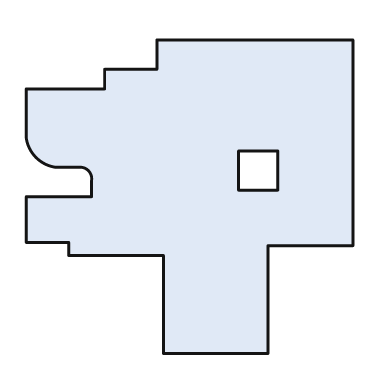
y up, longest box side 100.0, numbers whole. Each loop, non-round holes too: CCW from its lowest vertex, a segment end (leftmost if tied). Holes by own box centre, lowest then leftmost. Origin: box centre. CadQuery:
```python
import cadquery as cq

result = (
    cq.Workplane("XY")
    .moveTo(-8.0, -48.0)
    .lineTo(24.0, -48.0)
    .lineTo(24.0, -15.0)
    .lineTo(50.0, -15.0)
    .lineTo(50.0, 48.0)
    .lineTo(-10.0, 48.0)
    .lineTo(-10.0, 39.0)
    .lineTo(-26.0, 39.0)
    .lineTo(-26.0, 33.0)
    .lineTo(-50.0, 33.0)
    .lineTo(-50.0, 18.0)
    .threePointArc((-47.0, 12.0), (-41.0, 9.0))
    .lineTo(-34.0, 9.0)
    .threePointArc((-31.0, 8.0), (-30.0, 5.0))
    .lineTo(-30.0, 0.0)
    .lineTo(-50.0, 0.0)
    .lineTo(-50.0, -14.0)
    .lineTo(-37.0, -14.0)
    .lineTo(-37.0, -18.0)
    .lineTo(-8.0, -18.0)
    .close()
    .moveTo(15.0, 2.0)
    .lineTo(27.0, 2.0)
    .lineTo(27.0, 14.0)
    .lineTo(15.0, 14.0)
    .close()
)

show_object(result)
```